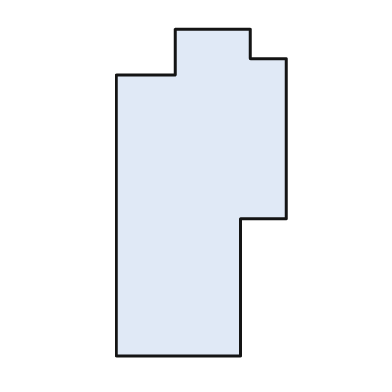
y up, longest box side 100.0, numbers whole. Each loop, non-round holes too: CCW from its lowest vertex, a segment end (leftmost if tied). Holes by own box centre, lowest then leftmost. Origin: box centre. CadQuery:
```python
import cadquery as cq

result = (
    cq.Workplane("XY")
    .moveTo(-26.0, -50.0)
    .lineTo(12.0, -50.0)
    .lineTo(12.0, -8.0)
    .lineTo(26.0, -8.0)
    .lineTo(26.0, 41.0)
    .lineTo(15.0, 41.0)
    .lineTo(15.0, 50.0)
    .lineTo(-8.0, 50.0)
    .lineTo(-8.0, 36.0)
    .lineTo(-26.0, 36.0)
    .close()
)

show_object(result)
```